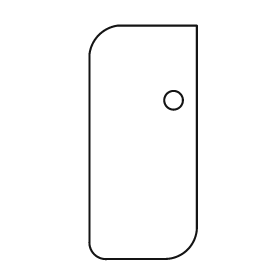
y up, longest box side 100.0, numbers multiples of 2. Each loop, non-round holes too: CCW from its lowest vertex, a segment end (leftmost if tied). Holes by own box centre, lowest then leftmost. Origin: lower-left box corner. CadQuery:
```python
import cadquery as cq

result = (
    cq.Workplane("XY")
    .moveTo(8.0, 0.0)
    .lineTo(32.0, 0.0)
    .threePointArc((42.0, 4.0), (46.0, 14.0))
    .lineTo(46.0, 100.0)
    .lineTo(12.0, 100.0)
    .threePointArc((4.0, 96.0), (0.0, 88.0))
    .lineTo(0.0, 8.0)
    .threePointArc((2.0, 2.0), (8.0, 0.0))
    .close()
    .moveTo(36.0, 68.0)
    .circle(4.0)
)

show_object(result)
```